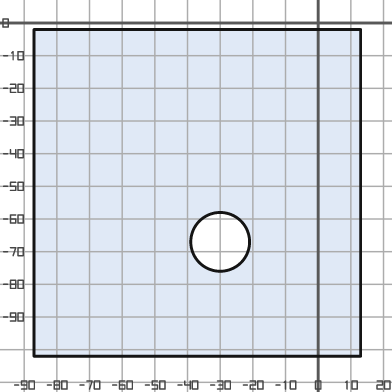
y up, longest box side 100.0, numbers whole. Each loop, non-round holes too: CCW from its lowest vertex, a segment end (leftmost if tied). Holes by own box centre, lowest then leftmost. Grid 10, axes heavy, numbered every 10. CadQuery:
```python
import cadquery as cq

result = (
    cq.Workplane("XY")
    .moveTo(-87.0, -102.0)
    .lineTo(13.0, -102.0)
    .lineTo(13.0, -2.0)
    .lineTo(-87.0, -2.0)
    .close()
    .moveTo(-30.0, -67.0)
    .circle(9.0)
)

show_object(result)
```